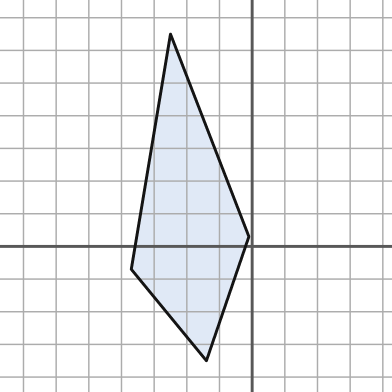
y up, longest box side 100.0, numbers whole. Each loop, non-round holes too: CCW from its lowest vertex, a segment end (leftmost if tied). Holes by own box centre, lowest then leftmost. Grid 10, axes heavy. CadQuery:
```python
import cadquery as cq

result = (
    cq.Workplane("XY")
    .moveTo(-14.0, -35.0)
    .lineTo(-1.0, 3.0)
    .lineTo(-25.0, 65.0)
    .lineTo(-37.0, -7.0)
    .close()
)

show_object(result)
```